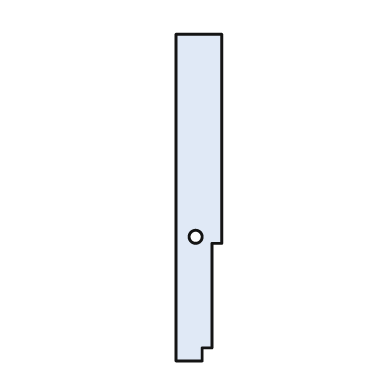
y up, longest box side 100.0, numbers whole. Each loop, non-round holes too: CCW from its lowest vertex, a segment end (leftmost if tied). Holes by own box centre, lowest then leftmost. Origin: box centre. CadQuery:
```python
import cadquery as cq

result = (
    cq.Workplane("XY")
    .moveTo(-7.0, -50.0)
    .lineTo(1.0, -50.0)
    .lineTo(1.0, -46.0)
    .lineTo(4.0, -46.0)
    .lineTo(4.0, -14.0)
    .lineTo(7.0, -14.0)
    .lineTo(7.0, 50.0)
    .lineTo(-7.0, 50.0)
    .close()
    .moveTo(-1.0, -12.0)
    .circle(2.0)
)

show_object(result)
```